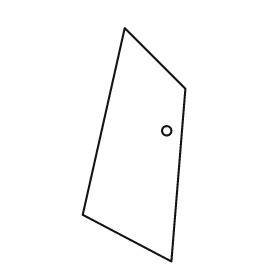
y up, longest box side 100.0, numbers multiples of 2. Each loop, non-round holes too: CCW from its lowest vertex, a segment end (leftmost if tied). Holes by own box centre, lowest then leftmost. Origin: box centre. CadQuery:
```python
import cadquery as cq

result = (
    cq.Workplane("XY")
    .moveTo(16.0, -50.0)
    .lineTo(22.0, 24.0)
    .lineTo(-4.0, 50.0)
    .lineTo(-22.0, -30.0)
    .close()
    .moveTo(14.0, 6.0)
    .circle(2.0)
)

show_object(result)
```